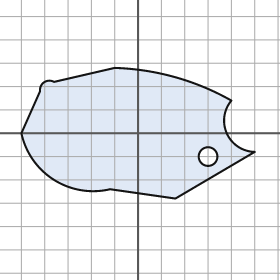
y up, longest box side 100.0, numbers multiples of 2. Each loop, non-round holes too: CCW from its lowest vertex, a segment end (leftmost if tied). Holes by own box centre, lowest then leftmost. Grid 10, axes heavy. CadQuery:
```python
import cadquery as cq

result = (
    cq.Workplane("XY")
    .moveTo(16.0, -28.0)
    .lineTo(50.0, -8.0)
    .threePointArc((38.0, 0.0), (40.0, 14.0))
    .threePointArc((16.0, 24.0), (-10.0, 28.0))
    .lineTo(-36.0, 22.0)
    .threePointArc((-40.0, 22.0), (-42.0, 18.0))
    .lineTo(-50.0, 0.0)
    .threePointArc((-36.0, -20.0), (-12.0, -24.0))
    .close()
    .moveTo(30.0, -10.0)
    .circle(4.0)
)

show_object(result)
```